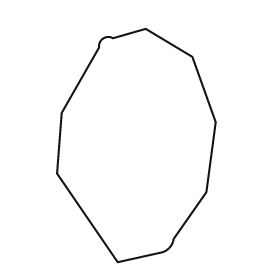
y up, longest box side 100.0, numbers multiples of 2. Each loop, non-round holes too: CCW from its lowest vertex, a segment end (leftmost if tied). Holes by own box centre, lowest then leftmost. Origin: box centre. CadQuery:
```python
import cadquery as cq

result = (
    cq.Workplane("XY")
    .moveTo(-8.0, -50.0)
    .lineTo(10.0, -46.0)
    .threePointArc((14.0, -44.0), (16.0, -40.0))
    .lineTo(30.0, -20.0)
    .lineTo(34.0, 10.0)
    .lineTo(24.0, 38.0)
    .lineTo(4.0, 50.0)
    .lineTo(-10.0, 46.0)
    .threePointArc((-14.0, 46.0), (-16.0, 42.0))
    .lineTo(-32.0, 14.0)
    .lineTo(-34.0, -12.0)
    .close()
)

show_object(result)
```